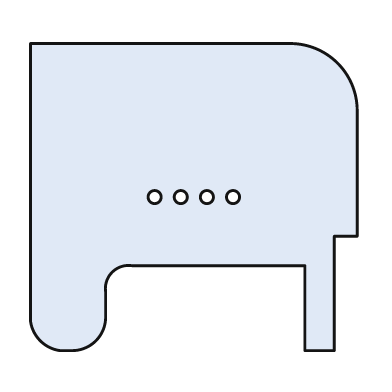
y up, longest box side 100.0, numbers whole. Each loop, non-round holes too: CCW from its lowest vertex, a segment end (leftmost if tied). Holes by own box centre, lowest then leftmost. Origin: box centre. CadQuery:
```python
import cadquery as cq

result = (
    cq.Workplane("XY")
    .moveTo(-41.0, -47.0)
    .lineTo(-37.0, -47.0)
    .threePointArc((-30.0, -44.0), (-27.0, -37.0))
    .lineTo(-27.0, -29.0)
    .threePointArc((-25.0, -23.0), (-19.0, -21.0))
    .lineTo(34.0, -21.0)
    .lineTo(34.0, -47.0)
    .lineTo(43.0, -47.0)
    .lineTo(43.0, -12.0)
    .lineTo(50.0, -12.0)
    .lineTo(50.0, 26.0)
    .threePointArc((44.0, 41.0), (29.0, 47.0))
    .lineTo(-50.0, 47.0)
    .lineTo(-50.0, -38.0)
    .threePointArc((-47.0, -44.0), (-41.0, -47.0))
    .close()
    .moveTo(-12.0, 0.0)
    .circle(2.0)
    .moveTo(-4.0, 0.0)
    .circle(2.0)
    .moveTo(4.0, 0.0)
    .circle(2.0)
    .moveTo(12.0, 0.0)
    .circle(2.0)
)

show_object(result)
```